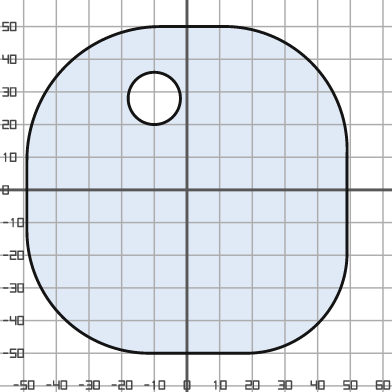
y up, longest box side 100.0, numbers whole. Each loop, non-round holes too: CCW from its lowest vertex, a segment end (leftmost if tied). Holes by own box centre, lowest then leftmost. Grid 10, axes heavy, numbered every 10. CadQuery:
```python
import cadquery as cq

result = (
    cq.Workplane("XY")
    .moveTo(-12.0, -50.0)
    .lineTo(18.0, -50.0)
    .threePointArc((40.0, -41.0), (49.0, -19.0))
    .lineTo(49.0, 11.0)
    .threePointArc((38.0, 39.0), (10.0, 50.0))
    .lineTo(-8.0, 50.0)
    .threePointArc((-37.0, 38.0), (-49.0, 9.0))
    .lineTo(-49.0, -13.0)
    .threePointArc((-38.0, -39.0), (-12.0, -50.0))
    .close()
    .moveTo(-10.0, 28.0)
    .circle(8.0)
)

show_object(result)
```